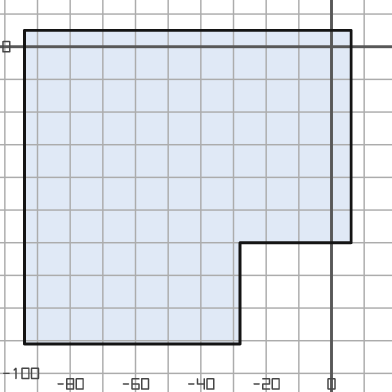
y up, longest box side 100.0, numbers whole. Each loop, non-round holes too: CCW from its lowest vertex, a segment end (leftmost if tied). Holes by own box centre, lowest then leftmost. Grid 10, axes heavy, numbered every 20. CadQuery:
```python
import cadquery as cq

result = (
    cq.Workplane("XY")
    .moveTo(-94.0, -91.0)
    .lineTo(-28.0, -91.0)
    .lineTo(-28.0, -60.0)
    .lineTo(6.0, -60.0)
    .lineTo(6.0, 5.0)
    .lineTo(-94.0, 5.0)
    .close()
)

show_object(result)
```